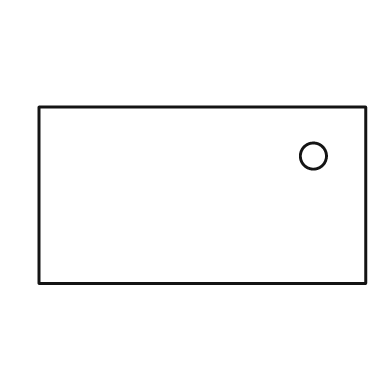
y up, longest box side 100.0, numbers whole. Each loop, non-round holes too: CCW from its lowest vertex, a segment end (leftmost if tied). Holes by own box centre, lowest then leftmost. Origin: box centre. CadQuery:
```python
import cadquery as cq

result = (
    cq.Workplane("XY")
    .moveTo(-50.0, -27.0)
    .lineTo(50.0, -27.0)
    .lineTo(50.0, 27.0)
    .lineTo(-50.0, 27.0)
    .close()
    .moveTo(34.0, 12.0)
    .circle(4.0)
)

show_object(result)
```